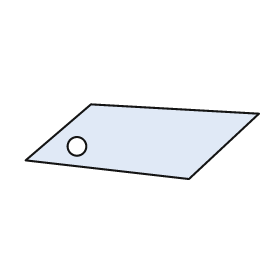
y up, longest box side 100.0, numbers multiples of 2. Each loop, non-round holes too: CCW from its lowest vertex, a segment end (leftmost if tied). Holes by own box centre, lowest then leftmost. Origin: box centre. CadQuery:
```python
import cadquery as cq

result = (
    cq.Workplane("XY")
    .moveTo(20.0, -16.0)
    .lineTo(50.0, 12.0)
    .lineTo(-22.0, 16.0)
    .lineTo(-50.0, -8.0)
    .close()
    .moveTo(-28.0, -2.0)
    .circle(4.0)
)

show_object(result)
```